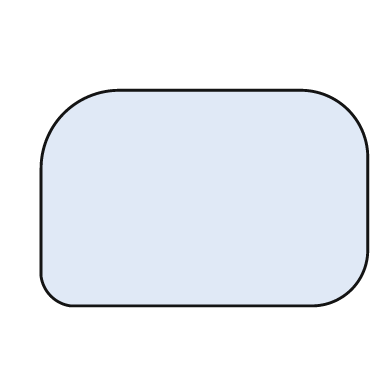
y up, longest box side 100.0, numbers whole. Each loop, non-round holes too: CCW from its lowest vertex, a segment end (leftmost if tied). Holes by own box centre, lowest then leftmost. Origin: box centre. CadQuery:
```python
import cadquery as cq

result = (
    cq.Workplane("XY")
    .moveTo(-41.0, -33.0)
    .lineTo(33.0, -33.0)
    .threePointArc((45.0, -28.0), (50.0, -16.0))
    .lineTo(50.0, 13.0)
    .threePointArc((44.0, 27.0), (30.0, 33.0))
    .lineTo(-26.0, 33.0)
    .threePointArc((-43.0, 26.0), (-50.0, 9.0))
    .lineTo(-50.0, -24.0)
    .threePointArc((-47.0, -30.0), (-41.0, -33.0))
    .close()
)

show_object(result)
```